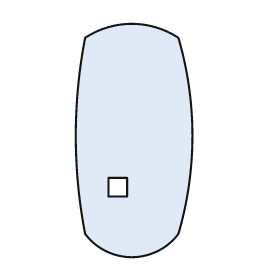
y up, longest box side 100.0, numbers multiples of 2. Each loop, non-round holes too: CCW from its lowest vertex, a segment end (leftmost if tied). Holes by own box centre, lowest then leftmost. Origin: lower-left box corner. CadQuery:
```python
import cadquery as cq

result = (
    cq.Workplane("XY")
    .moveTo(4.0, 10.0)
    .threePointArc((24.0, 0.0), (44.0, 10.0))
    .threePointArc((50.0, 52.0), (44.0, 94.0))
    .threePointArc((24.0, 100.0), (4.0, 94.0))
    .threePointArc((0.0, 52.0), (4.0, 10.0))
    .close()
    .moveTo(14.0, 26.0)
    .lineTo(22.0, 26.0)
    .lineTo(22.0, 34.0)
    .lineTo(14.0, 34.0)
    .close()
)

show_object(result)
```